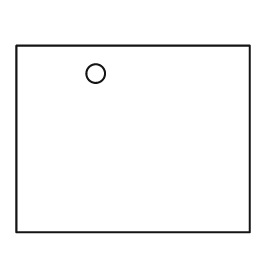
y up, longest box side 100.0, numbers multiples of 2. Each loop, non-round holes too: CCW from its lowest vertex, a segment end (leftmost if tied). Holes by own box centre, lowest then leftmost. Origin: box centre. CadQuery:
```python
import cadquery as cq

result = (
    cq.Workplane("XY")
    .moveTo(-50.0, -40.0)
    .lineTo(50.0, -40.0)
    .lineTo(50.0, 40.0)
    .lineTo(-50.0, 40.0)
    .close()
    .moveTo(-16.0, 28.0)
    .circle(4.0)
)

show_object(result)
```